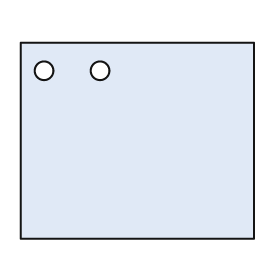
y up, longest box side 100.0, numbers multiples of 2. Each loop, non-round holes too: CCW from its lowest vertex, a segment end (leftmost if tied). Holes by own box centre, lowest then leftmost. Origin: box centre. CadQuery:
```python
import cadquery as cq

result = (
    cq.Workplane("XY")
    .moveTo(-50.0, -42.0)
    .lineTo(50.0, -42.0)
    .lineTo(50.0, 42.0)
    .lineTo(-50.0, 42.0)
    .close()
    .moveTo(-40.0, 30.0)
    .circle(4.0)
    .moveTo(-16.0, 30.0)
    .circle(4.0)
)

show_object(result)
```